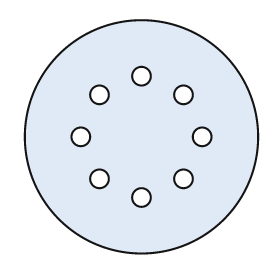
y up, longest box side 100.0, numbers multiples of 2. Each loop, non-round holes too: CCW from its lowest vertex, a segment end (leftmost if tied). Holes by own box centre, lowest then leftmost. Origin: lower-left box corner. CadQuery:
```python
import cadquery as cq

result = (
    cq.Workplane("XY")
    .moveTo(50.0, 50.0)
    .circle(50.0)
    .moveTo(50.0, 24.0)
    .circle(4.0)
    .moveTo(32.0, 32.0)
    .circle(4.0)
    .moveTo(68.0, 32.0)
    .circle(4.0)
    .moveTo(24.0, 50.0)
    .circle(4.0)
    .moveTo(76.0, 50.0)
    .circle(4.0)
    .moveTo(32.0, 68.0)
    .circle(4.0)
    .moveTo(68.0, 68.0)
    .circle(4.0)
    .moveTo(50.0, 76.0)
    .circle(4.0)
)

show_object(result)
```